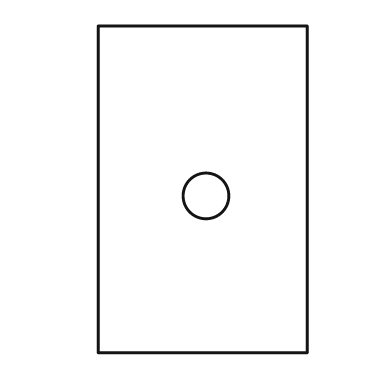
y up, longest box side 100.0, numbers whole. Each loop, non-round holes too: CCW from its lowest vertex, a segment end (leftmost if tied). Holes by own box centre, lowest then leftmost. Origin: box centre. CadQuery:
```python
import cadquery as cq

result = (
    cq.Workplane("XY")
    .moveTo(-32.0, -50.0)
    .lineTo(32.0, -50.0)
    .lineTo(32.0, 50.0)
    .lineTo(-32.0, 50.0)
    .close()
    .moveTo(1.0, -2.0)
    .circle(7.0)
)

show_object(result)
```